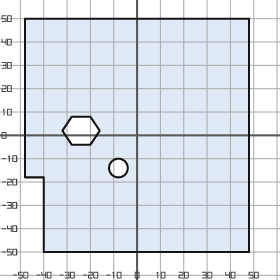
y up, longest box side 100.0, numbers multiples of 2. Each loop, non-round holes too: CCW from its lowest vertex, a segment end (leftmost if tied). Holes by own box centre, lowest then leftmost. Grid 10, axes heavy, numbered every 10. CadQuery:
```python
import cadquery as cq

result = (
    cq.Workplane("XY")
    .moveTo(-40.0, -50.0)
    .lineTo(48.0, -50.0)
    .lineTo(48.0, 50.0)
    .lineTo(-48.0, 50.0)
    .lineTo(-48.0, -18.0)
    .lineTo(-40.0, -18.0)
    .close()
    .moveTo(-8.0, -14.0)
    .circle(4.0)
    .moveTo(-28.0, -4.0)
    .lineTo(-20.0, -4.0)
    .lineTo(-16.0, 2.0)
    .lineTo(-20.0, 8.0)
    .lineTo(-28.0, 8.0)
    .lineTo(-32.0, 2.0)
    .close()
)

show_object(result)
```